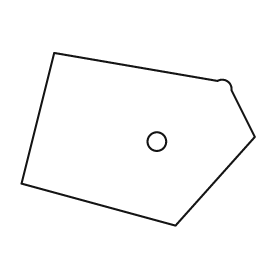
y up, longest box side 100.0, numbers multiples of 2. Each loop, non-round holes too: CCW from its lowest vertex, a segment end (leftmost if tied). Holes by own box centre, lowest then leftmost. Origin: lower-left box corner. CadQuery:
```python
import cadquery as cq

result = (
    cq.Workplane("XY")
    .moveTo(66.0, 0.0)
    .lineTo(100.0, 38.0)
    .lineTo(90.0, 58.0)
    .threePointArc((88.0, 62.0), (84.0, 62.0))
    .lineTo(14.0, 74.0)
    .lineTo(0.0, 18.0)
    .close()
    .moveTo(58.0, 36.0)
    .circle(4.0)
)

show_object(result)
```